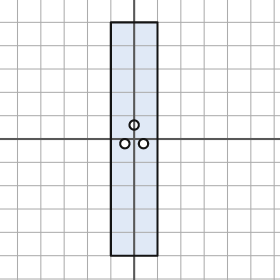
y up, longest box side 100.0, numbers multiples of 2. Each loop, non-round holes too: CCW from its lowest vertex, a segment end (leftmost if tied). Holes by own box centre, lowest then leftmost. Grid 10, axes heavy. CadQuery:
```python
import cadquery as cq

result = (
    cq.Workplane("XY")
    .moveTo(-10.0, -50.0)
    .lineTo(10.0, -50.0)
    .lineTo(10.0, 50.0)
    .lineTo(-10.0, 50.0)
    .close()
    .moveTo(-4.0, -2.0)
    .circle(2.0)
    .moveTo(4.0, -2.0)
    .circle(2.0)
    .moveTo(0.0, 6.0)
    .circle(2.0)
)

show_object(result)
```